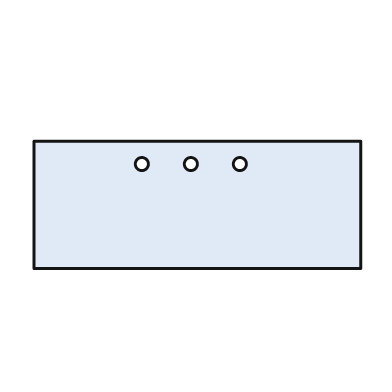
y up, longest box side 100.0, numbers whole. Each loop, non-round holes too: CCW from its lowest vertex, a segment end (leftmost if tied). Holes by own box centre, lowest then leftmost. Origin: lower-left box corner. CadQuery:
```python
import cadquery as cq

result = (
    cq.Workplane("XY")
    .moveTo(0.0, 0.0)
    .lineTo(100.0, 0.0)
    .lineTo(100.0, 39.0)
    .lineTo(0.0, 39.0)
    .close()
    .moveTo(33.0, 32.0)
    .circle(2.0)
    .moveTo(48.0, 32.0)
    .circle(2.0)
    .moveTo(63.0, 32.0)
    .circle(2.0)
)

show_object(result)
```